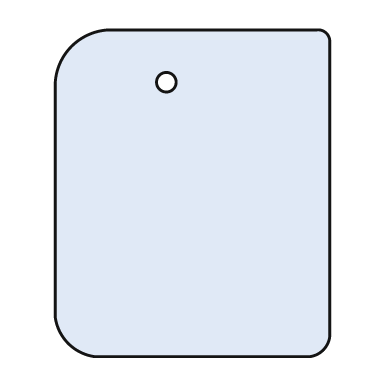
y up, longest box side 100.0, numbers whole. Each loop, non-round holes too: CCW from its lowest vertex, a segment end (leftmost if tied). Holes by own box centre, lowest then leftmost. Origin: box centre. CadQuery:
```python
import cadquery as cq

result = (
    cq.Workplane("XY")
    .moveTo(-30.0, -50.0)
    .lineTo(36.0, -50.0)
    .threePointArc((40.0, -48.0), (42.0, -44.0))
    .lineTo(42.0, 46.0)
    .threePointArc((41.0, 49.0), (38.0, 50.0))
    .lineTo(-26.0, 50.0)
    .threePointArc((-37.0, 45.0), (-42.0, 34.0))
    .lineTo(-42.0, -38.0)
    .threePointArc((-38.0, -46.0), (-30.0, -50.0))
    .close()
    .moveTo(-8.0, 34.0)
    .circle(3.0)
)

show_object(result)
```